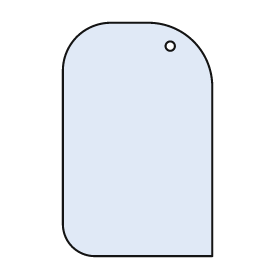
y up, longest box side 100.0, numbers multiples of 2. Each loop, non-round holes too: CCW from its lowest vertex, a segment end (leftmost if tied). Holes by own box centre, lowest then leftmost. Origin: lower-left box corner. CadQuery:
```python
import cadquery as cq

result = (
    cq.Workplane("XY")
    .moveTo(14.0, 0.0)
    .lineTo(64.0, 0.0)
    .lineTo(64.0, 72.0)
    .threePointArc((56.0, 92.0), (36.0, 100.0))
    .lineTo(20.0, 100.0)
    .threePointArc((6.0, 94.0), (0.0, 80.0))
    .lineTo(0.0, 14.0)
    .threePointArc((4.0, 4.0), (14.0, 0.0))
    .close()
    .moveTo(46.0, 90.0)
    .circle(2.0)
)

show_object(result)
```